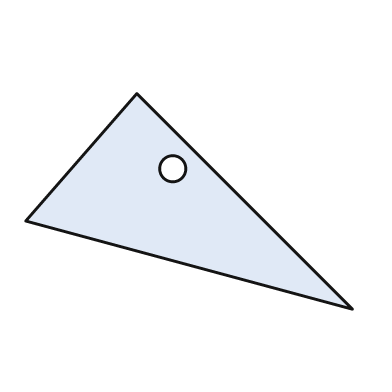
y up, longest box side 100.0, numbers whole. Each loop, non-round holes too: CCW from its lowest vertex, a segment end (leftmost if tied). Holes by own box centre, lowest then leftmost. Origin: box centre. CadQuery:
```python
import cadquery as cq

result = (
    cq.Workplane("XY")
    .moveTo(50.0, -33.0)
    .lineTo(-16.0, 33.0)
    .lineTo(-50.0, -6.0)
    .close()
    .moveTo(-5.0, 10.0)
    .circle(4.0)
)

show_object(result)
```